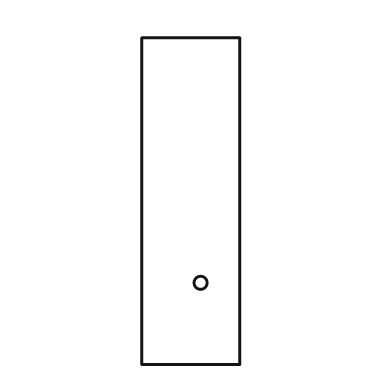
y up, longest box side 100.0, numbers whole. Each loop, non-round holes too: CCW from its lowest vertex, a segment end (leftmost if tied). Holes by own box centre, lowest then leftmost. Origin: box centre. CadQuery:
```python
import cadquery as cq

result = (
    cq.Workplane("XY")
    .moveTo(-15.0, -50.0)
    .lineTo(15.0, -50.0)
    .lineTo(15.0, 50.0)
    .lineTo(-15.0, 50.0)
    .close()
    .moveTo(3.0, -25.0)
    .circle(2.0)
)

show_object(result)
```